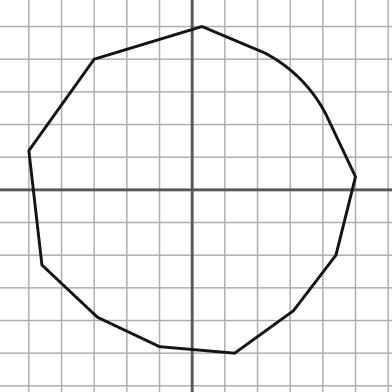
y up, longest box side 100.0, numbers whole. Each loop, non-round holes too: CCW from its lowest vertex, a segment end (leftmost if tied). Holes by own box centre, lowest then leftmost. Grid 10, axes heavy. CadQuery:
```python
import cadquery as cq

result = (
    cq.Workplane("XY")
    .moveTo(13.0, -50.0)
    .lineTo(31.0, -37.0)
    .lineTo(44.0, -20.0)
    .lineTo(50.0, 4.0)
    .lineTo(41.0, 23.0)
    .threePointArc((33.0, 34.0), (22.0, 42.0))
    .lineTo(3.0, 50.0)
    .lineTo(-30.0, 40.0)
    .lineTo(-50.0, 12.0)
    .lineTo(-46.0, -23.0)
    .lineTo(-29.0, -39.0)
    .lineTo(-10.0, -48.0)
    .close()
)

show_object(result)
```